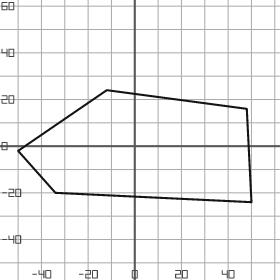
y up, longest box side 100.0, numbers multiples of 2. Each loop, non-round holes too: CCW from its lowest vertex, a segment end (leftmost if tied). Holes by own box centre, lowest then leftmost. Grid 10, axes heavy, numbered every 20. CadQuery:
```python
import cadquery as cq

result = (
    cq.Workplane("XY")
    .moveTo(50.0, -24.0)
    .lineTo(48.0, 16.0)
    .lineTo(-12.0, 24.0)
    .lineTo(-50.0, -2.0)
    .lineTo(-34.0, -20.0)
    .close()
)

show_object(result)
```